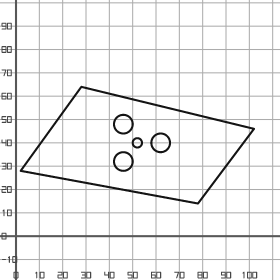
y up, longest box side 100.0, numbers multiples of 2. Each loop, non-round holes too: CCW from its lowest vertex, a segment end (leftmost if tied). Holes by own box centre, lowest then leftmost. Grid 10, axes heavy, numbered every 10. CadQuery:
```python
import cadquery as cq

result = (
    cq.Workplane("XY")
    .moveTo(78.0, 14.0)
    .lineTo(102.0, 46.0)
    .lineTo(28.0, 64.0)
    .lineTo(2.0, 28.0)
    .close()
    .moveTo(46.0, 32.0)
    .circle(4.0)
    .moveTo(52.0, 40.0)
    .circle(2.0)
    .moveTo(62.0, 40.0)
    .circle(4.0)
    .moveTo(46.0, 48.0)
    .circle(4.0)
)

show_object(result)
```